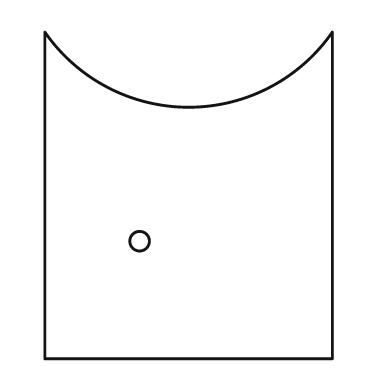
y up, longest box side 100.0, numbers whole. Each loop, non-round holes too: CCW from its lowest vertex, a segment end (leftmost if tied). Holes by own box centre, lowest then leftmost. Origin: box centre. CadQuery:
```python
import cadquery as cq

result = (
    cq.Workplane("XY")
    .moveTo(-44.0, -50.0)
    .lineTo(44.0, -50.0)
    .lineTo(44.0, 50.0)
    .threePointArc((0.0, 27.0), (-44.0, 50.0))
    .close()
    .moveTo(-15.0, -14.0)
    .circle(3.0)
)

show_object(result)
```